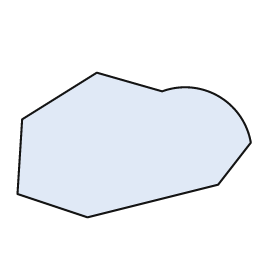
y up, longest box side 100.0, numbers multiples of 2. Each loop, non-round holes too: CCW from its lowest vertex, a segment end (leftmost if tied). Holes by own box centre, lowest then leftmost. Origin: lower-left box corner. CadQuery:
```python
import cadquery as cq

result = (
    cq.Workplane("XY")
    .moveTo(30.0, 0.0)
    .lineTo(86.0, 14.0)
    .lineTo(100.0, 32.0)
    .threePointArc((86.0, 52.0), (62.0, 54.0))
    .lineTo(34.0, 62.0)
    .lineTo(2.0, 42.0)
    .lineTo(0.0, 10.0)
    .close()
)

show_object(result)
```